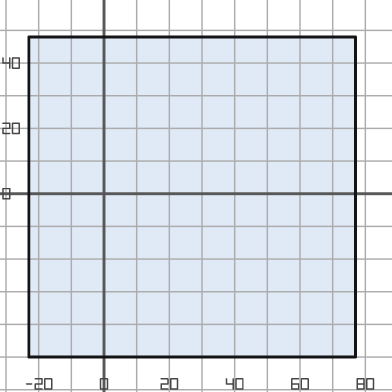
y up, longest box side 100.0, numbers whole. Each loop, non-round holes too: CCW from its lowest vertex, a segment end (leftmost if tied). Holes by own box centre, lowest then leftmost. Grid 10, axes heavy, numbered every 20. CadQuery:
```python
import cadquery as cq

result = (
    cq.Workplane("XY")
    .moveTo(-23.0, -50.0)
    .lineTo(77.0, -50.0)
    .lineTo(77.0, 48.0)
    .lineTo(-23.0, 48.0)
    .close()
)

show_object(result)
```